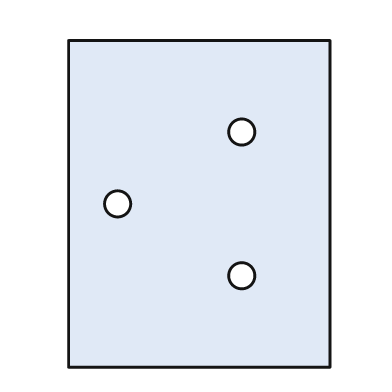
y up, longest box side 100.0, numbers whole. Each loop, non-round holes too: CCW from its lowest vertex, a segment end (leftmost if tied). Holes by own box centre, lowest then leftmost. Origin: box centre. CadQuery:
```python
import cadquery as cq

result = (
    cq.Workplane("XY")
    .moveTo(-40.0, -50.0)
    .lineTo(40.0, -50.0)
    .lineTo(40.0, 50.0)
    .lineTo(-40.0, 50.0)
    .close()
    .moveTo(13.0, -22.0)
    .circle(4.0)
    .moveTo(-25.0, 0.0)
    .circle(4.0)
    .moveTo(13.0, 22.0)
    .circle(4.0)
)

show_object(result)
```